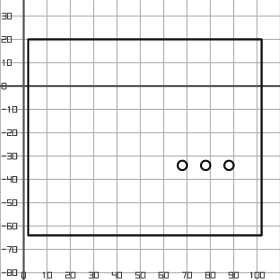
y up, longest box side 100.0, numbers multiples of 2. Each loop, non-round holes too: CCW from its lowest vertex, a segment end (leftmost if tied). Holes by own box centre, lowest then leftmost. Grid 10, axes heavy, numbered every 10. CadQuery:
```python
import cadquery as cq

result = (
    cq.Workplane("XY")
    .moveTo(2.0, -64.0)
    .lineTo(102.0, -64.0)
    .lineTo(102.0, 20.0)
    .lineTo(2.0, 20.0)
    .close()
    .moveTo(68.0, -34.0)
    .circle(2.0)
    .moveTo(78.0, -34.0)
    .circle(2.0)
    .moveTo(88.0, -34.0)
    .circle(2.0)
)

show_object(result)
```